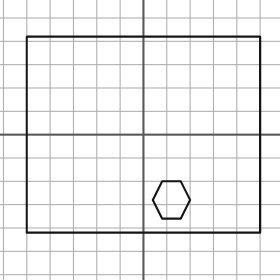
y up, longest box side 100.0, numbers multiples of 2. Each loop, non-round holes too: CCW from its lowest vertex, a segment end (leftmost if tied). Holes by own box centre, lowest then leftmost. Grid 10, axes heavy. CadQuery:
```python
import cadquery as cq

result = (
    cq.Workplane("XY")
    .moveTo(-50.0, -42.0)
    .lineTo(50.0, -42.0)
    .lineTo(50.0, 42.0)
    .lineTo(-50.0, 42.0)
    .close()
    .moveTo(8.0, -36.0)
    .lineTo(16.0, -36.0)
    .lineTo(20.0, -28.0)
    .lineTo(16.0, -20.0)
    .lineTo(8.0, -20.0)
    .lineTo(4.0, -28.0)
    .close()
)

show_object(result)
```